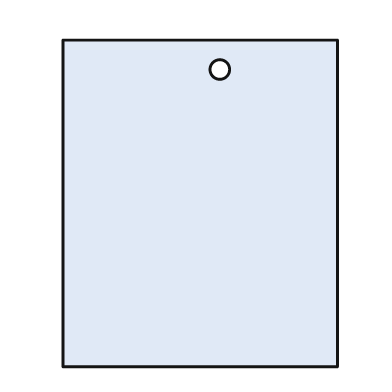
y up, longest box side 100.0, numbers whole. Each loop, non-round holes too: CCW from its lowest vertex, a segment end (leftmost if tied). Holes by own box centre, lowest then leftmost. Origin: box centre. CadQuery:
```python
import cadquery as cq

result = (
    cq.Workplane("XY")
    .moveTo(-42.0, -50.0)
    .lineTo(42.0, -50.0)
    .lineTo(42.0, 50.0)
    .lineTo(-42.0, 50.0)
    .close()
    .moveTo(6.0, 41.0)
    .circle(3.0)
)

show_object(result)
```